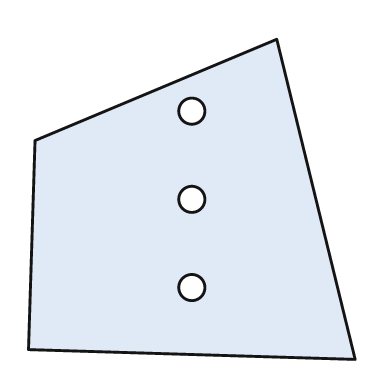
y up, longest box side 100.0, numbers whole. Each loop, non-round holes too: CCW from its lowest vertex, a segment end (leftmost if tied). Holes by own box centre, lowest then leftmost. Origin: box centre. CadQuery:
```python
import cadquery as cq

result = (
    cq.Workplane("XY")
    .moveTo(50.0, -49.0)
    .lineTo(26.0, 49.0)
    .lineTo(-48.0, 18.0)
    .lineTo(-50.0, -46.0)
    .close()
    .moveTo(0.0, -27.0)
    .circle(4.0)
    .moveTo(0.0, 0.0)
    .circle(4.0)
    .moveTo(0.0, 27.0)
    .circle(4.0)
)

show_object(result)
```